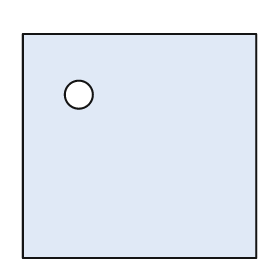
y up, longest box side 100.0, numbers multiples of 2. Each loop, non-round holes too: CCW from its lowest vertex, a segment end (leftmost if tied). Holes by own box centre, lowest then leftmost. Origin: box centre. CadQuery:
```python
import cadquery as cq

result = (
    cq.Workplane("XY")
    .moveTo(-50.0, -48.0)
    .lineTo(50.0, -48.0)
    .lineTo(50.0, 48.0)
    .lineTo(-50.0, 48.0)
    .close()
    .moveTo(-26.0, 22.0)
    .circle(6.0)
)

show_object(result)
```